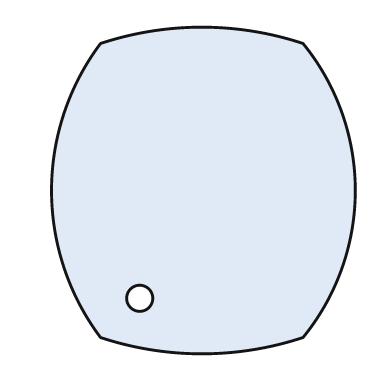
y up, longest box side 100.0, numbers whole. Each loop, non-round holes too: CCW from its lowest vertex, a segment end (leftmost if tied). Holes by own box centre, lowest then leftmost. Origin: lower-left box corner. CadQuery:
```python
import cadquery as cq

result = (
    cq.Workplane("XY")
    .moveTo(15.0, 5.0)
    .threePointArc((46.0, 0.0), (77.0, 5.0))
    .threePointArc((93.0, 50.0), (77.0, 95.0))
    .threePointArc((46.0, 100.0), (15.0, 95.0))
    .threePointArc((0.0, 50.0), (15.0, 5.0))
    .close()
    .moveTo(27.0, 17.0)
    .circle(4.0)
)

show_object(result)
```